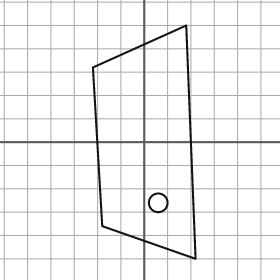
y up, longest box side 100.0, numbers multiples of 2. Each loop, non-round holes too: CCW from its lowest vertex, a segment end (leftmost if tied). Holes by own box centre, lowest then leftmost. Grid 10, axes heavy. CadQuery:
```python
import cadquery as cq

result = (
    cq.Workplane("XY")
    .moveTo(22.0, -50.0)
    .lineTo(18.0, 50.0)
    .lineTo(-22.0, 32.0)
    .lineTo(-18.0, -36.0)
    .close()
    .moveTo(6.0, -26.0)
    .circle(4.0)
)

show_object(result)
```